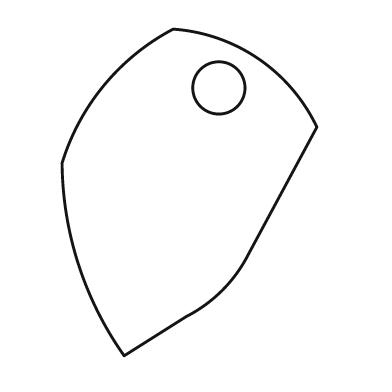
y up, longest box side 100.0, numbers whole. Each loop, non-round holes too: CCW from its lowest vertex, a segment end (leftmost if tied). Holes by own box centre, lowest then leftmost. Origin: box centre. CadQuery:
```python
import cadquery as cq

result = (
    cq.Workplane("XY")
    .moveTo(-20.0, -50.0)
    .lineTo(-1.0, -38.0)
    .threePointArc((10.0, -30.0), (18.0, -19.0))
    .lineTo(39.0, 20.0)
    .threePointArc((21.0, 41.0), (-5.0, 50.0))
    .threePointArc((-26.0, 33.0), (-39.0, 9.0))
    .threePointArc((-34.0, -22.0), (-20.0, -50.0))
    .close()
    .moveTo(9.0, 32.0)
    .circle(8.0)
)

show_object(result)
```